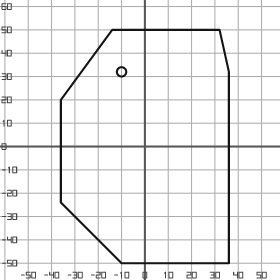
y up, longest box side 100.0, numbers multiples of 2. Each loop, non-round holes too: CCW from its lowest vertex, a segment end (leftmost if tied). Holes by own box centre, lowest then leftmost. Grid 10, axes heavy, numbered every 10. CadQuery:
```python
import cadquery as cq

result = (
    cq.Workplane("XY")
    .moveTo(-10.0, -50.0)
    .lineTo(36.0, -50.0)
    .lineTo(36.0, 32.0)
    .lineTo(32.0, 50.0)
    .lineTo(-14.0, 50.0)
    .lineTo(-36.0, 20.0)
    .lineTo(-36.0, -24.0)
    .close()
    .moveTo(-10.0, 32.0)
    .circle(2.0)
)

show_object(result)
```